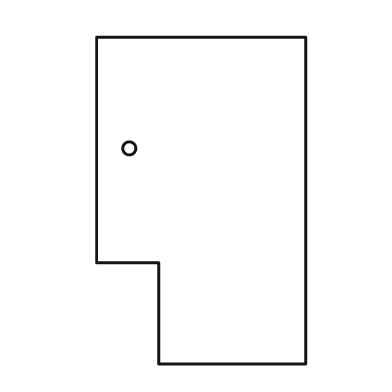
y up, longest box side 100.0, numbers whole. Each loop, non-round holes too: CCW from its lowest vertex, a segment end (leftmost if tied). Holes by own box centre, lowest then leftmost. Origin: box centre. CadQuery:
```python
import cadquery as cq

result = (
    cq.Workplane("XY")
    .moveTo(-13.0, -50.0)
    .lineTo(32.0, -50.0)
    .lineTo(32.0, 50.0)
    .lineTo(-32.0, 50.0)
    .lineTo(-32.0, -19.0)
    .lineTo(-13.0, -19.0)
    .close()
    .moveTo(-22.0, 16.0)
    .circle(2.0)
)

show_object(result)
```